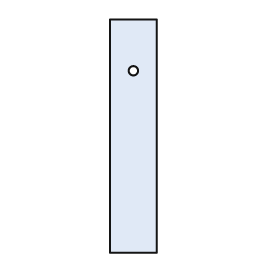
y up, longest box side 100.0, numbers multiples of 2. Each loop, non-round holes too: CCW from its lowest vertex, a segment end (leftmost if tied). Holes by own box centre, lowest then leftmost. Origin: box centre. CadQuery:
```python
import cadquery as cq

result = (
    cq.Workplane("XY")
    .moveTo(-10.0, -50.0)
    .lineTo(10.0, -50.0)
    .lineTo(10.0, 50.0)
    .lineTo(-10.0, 50.0)
    .close()
    .moveTo(0.0, 28.0)
    .circle(2.0)
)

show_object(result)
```